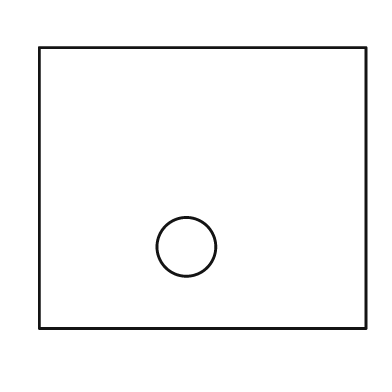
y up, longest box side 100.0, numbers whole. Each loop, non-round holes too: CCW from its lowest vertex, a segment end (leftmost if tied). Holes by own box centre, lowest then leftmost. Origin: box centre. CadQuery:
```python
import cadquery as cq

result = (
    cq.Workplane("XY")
    .moveTo(-50.0, -43.0)
    .lineTo(50.0, -43.0)
    .lineTo(50.0, 43.0)
    .lineTo(-50.0, 43.0)
    .close()
    .moveTo(-5.0, -18.0)
    .circle(9.0)
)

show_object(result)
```